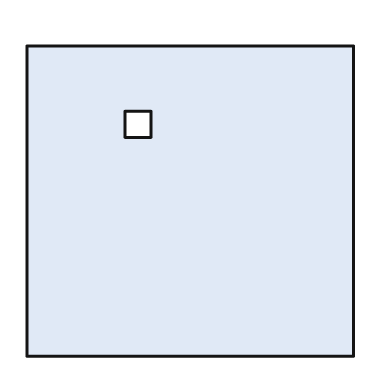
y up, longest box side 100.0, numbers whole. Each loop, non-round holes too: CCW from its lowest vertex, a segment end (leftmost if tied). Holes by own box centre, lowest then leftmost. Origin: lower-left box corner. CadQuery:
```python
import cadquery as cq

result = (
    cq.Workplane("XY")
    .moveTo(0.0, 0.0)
    .lineTo(100.0, 0.0)
    .lineTo(100.0, 95.0)
    .lineTo(0.0, 95.0)
    .close()
    .moveTo(30.0, 67.0)
    .lineTo(38.0, 67.0)
    .lineTo(38.0, 75.0)
    .lineTo(30.0, 75.0)
    .close()
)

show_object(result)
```